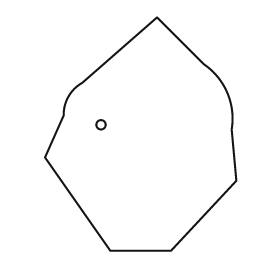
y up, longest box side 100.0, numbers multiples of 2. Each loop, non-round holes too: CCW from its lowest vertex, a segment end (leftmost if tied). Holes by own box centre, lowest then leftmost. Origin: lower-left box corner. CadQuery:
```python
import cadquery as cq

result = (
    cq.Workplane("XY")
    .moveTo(28.0, 0.0)
    .lineTo(54.0, 0.0)
    .lineTo(82.0, 30.0)
    .lineTo(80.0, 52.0)
    .threePointArc((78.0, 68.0), (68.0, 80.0))
    .lineTo(48.0, 100.0)
    .lineTo(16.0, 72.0)
    .threePointArc((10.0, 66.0), (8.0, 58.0))
    .lineTo(0.0, 40.0)
    .close()
    .moveTo(24.0, 54.0)
    .circle(2.0)
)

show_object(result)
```